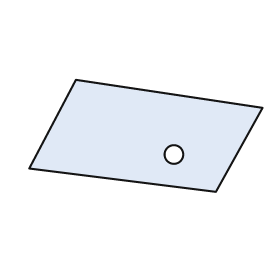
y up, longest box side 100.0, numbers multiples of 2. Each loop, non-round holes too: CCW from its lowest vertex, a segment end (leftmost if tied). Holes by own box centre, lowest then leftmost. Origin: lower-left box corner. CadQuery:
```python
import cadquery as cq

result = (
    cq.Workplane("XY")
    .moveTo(80.0, 0.0)
    .lineTo(100.0, 36.0)
    .lineTo(20.0, 48.0)
    .lineTo(0.0, 10.0)
    .close()
    .moveTo(62.0, 16.0)
    .circle(4.0)
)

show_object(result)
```